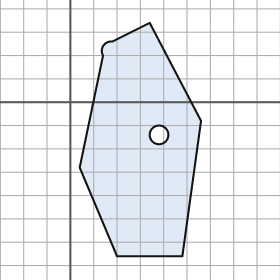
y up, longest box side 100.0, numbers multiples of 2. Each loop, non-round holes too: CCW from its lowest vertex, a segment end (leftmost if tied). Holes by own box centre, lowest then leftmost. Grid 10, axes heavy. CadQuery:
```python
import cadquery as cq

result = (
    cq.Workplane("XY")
    .moveTo(20.0, -66.0)
    .lineTo(48.0, -66.0)
    .lineTo(56.0, -8.0)
    .lineTo(34.0, 34.0)
    .lineTo(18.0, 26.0)
    .threePointArc((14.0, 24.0), (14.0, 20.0))
    .lineTo(4.0, -28.0)
    .close()
    .moveTo(38.0, -14.0)
    .circle(4.0)
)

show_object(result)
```